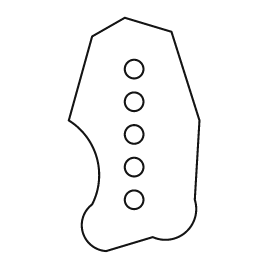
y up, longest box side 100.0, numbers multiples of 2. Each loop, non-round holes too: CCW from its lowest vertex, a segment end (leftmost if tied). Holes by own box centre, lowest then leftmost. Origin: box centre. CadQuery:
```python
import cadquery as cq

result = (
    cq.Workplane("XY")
    .moveTo(-12.0, -50.0)
    .lineTo(8.0, -44.0)
    .threePointArc((22.0, -42.0), (26.0, -28.0))
    .lineTo(28.0, 6.0)
    .lineTo(16.0, 44.0)
    .lineTo(-4.0, 50.0)
    .lineTo(-18.0, 42.0)
    .lineTo(-28.0, 6.0)
    .threePointArc((-16.0, -10.0), (-18.0, -30.0))
    .threePointArc((-22.0, -42.0), (-12.0, -50.0))
    .close()
    .moveTo(0.0, -28.0)
    .circle(4.0)
    .moveTo(0.0, -14.0)
    .circle(4.0)
    .moveTo(0.0, 0.0)
    .circle(4.0)
    .moveTo(0.0, 14.0)
    .circle(4.0)
    .moveTo(0.0, 28.0)
    .circle(4.0)
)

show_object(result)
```